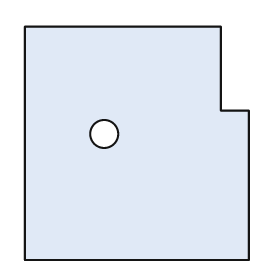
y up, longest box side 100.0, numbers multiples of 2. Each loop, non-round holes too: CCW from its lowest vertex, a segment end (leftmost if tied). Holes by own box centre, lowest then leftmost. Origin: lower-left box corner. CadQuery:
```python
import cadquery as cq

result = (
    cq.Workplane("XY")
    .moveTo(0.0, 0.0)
    .lineTo(96.0, 0.0)
    .lineTo(96.0, 64.0)
    .lineTo(84.0, 64.0)
    .lineTo(84.0, 100.0)
    .lineTo(0.0, 100.0)
    .close()
    .moveTo(34.0, 54.0)
    .circle(6.0)
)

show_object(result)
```